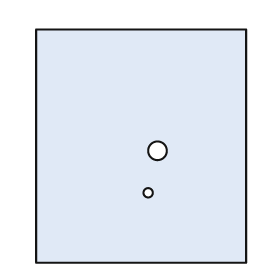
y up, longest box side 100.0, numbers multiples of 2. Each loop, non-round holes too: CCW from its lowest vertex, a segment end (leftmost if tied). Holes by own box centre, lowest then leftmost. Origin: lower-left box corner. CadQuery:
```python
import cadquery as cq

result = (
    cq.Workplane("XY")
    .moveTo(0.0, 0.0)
    .lineTo(90.0, 0.0)
    .lineTo(90.0, 100.0)
    .lineTo(0.0, 100.0)
    .close()
    .moveTo(48.0, 30.0)
    .circle(2.0)
    .moveTo(52.0, 48.0)
    .circle(4.0)
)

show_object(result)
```